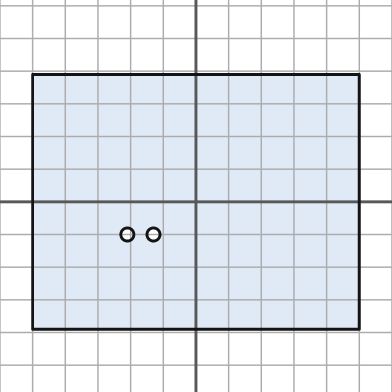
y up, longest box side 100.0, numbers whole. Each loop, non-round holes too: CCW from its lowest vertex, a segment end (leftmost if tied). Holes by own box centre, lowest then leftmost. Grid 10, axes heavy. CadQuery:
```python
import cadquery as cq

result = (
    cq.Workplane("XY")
    .moveTo(-50.0, -39.0)
    .lineTo(50.0, -39.0)
    .lineTo(50.0, 39.0)
    .lineTo(-50.0, 39.0)
    .close()
    .moveTo(-21.0, -10.0)
    .circle(2.0)
    .moveTo(-13.0, -10.0)
    .circle(2.0)
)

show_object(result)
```